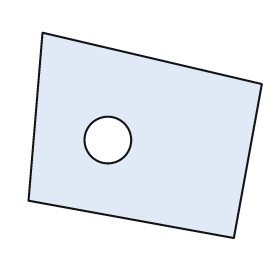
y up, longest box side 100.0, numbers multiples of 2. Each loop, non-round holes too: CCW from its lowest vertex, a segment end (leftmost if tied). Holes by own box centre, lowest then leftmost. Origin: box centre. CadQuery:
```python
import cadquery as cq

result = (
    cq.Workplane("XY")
    .moveTo(38.0, -44.0)
    .lineTo(50.0, 22.0)
    .lineTo(-44.0, 44.0)
    .lineTo(-50.0, -28.0)
    .close()
    .moveTo(-16.0, -2.0)
    .circle(10.0)
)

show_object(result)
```